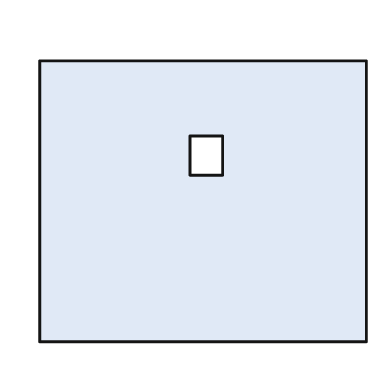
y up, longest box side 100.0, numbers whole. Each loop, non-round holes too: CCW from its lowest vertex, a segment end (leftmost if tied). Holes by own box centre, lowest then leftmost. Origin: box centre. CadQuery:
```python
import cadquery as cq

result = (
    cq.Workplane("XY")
    .moveTo(-50.0, -43.0)
    .lineTo(50.0, -43.0)
    .lineTo(50.0, 43.0)
    .lineTo(-50.0, 43.0)
    .close()
    .moveTo(-4.0, 8.0)
    .lineTo(6.0, 8.0)
    .lineTo(6.0, 20.0)
    .lineTo(-4.0, 20.0)
    .close()
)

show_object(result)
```